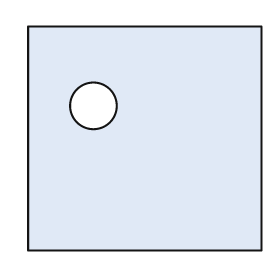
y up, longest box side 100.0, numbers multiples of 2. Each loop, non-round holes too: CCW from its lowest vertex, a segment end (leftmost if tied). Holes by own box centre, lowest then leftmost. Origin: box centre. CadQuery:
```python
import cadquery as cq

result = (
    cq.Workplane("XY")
    .moveTo(-50.0, -48.0)
    .lineTo(50.0, -48.0)
    .lineTo(50.0, 48.0)
    .lineTo(-50.0, 48.0)
    .close()
    .moveTo(-22.0, 14.0)
    .circle(10.0)
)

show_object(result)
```